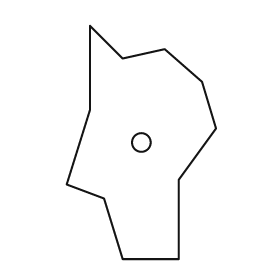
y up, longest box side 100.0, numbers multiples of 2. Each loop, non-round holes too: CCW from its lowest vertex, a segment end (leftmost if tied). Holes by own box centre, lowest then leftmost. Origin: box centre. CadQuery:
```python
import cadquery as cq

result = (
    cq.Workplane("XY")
    .moveTo(-8.0, -50.0)
    .lineTo(16.0, -50.0)
    .lineTo(16.0, -16.0)
    .lineTo(32.0, 6.0)
    .lineTo(26.0, 26.0)
    .lineTo(10.0, 40.0)
    .lineTo(-8.0, 36.0)
    .lineTo(-22.0, 50.0)
    .lineTo(-22.0, 14.0)
    .lineTo(-32.0, -18.0)
    .lineTo(-16.0, -24.0)
    .close()
    .moveTo(0.0, 0.0)
    .circle(4.0)
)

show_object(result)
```